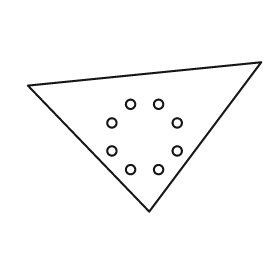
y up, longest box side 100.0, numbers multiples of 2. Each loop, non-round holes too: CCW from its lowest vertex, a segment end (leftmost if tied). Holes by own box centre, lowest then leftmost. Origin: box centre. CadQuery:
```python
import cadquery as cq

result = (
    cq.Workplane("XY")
    .moveTo(2.0, -32.0)
    .lineTo(50.0, 32.0)
    .lineTo(-50.0, 22.0)
    .close()
    .moveTo(-6.0, -14.0)
    .circle(2.0)
    .moveTo(6.0, -14.0)
    .circle(2.0)
    .moveTo(-14.0, -6.0)
    .circle(2.0)
    .moveTo(14.0, -6.0)
    .circle(2.0)
    .moveTo(-14.0, 6.0)
    .circle(2.0)
    .moveTo(14.0, 6.0)
    .circle(2.0)
    .moveTo(-6.0, 14.0)
    .circle(2.0)
    .moveTo(6.0, 14.0)
    .circle(2.0)
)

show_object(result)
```